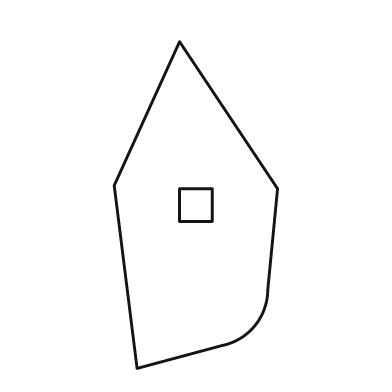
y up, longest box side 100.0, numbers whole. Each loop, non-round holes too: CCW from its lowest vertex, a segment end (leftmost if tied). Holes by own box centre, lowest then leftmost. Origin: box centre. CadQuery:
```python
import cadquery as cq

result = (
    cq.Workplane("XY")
    .moveTo(-18.0, -50.0)
    .lineTo(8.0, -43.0)
    .threePointArc((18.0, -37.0), (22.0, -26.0))
    .lineTo(25.0, 5.0)
    .lineTo(-5.0, 50.0)
    .lineTo(-25.0, 6.0)
    .close()
    .moveTo(-5.0, -5.0)
    .lineTo(5.0, -5.0)
    .lineTo(5.0, 5.0)
    .lineTo(-5.0, 5.0)
    .close()
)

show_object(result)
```